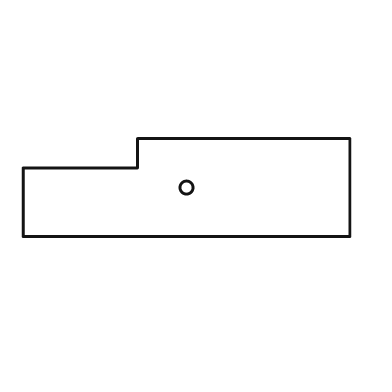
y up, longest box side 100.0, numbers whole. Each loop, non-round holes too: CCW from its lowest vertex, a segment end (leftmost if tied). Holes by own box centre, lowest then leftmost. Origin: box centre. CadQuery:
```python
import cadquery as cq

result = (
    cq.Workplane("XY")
    .moveTo(-50.0, -15.0)
    .lineTo(50.0, -15.0)
    .lineTo(50.0, 15.0)
    .lineTo(-15.0, 15.0)
    .lineTo(-15.0, 6.0)
    .lineTo(-50.0, 6.0)
    .close()
    .moveTo(0.0, 0.0)
    .circle(2.0)
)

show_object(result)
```